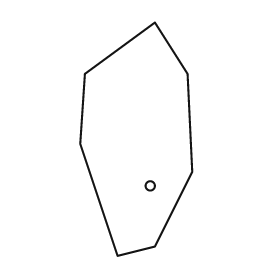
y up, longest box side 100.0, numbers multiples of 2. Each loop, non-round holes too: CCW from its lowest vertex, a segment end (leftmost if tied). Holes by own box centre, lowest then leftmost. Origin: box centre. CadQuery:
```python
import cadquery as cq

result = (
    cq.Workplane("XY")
    .moveTo(-8.0, -50.0)
    .lineTo(8.0, -46.0)
    .lineTo(24.0, -14.0)
    .lineTo(22.0, 28.0)
    .lineTo(8.0, 50.0)
    .lineTo(-22.0, 28.0)
    .lineTo(-24.0, -2.0)
    .close()
    .moveTo(6.0, -20.0)
    .circle(2.0)
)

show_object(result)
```